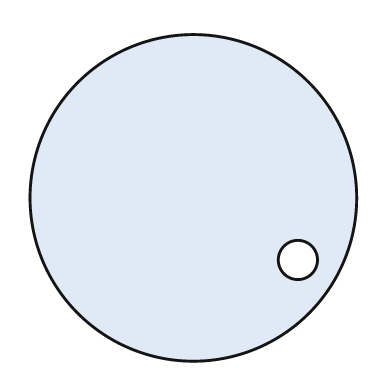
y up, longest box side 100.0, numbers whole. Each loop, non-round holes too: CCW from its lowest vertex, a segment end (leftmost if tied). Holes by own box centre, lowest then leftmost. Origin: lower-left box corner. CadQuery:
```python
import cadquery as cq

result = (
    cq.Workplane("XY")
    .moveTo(50.0, 50.0)
    .circle(50.0)
    .moveTo(82.0, 31.0)
    .circle(6.0)
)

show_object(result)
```